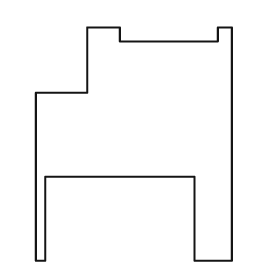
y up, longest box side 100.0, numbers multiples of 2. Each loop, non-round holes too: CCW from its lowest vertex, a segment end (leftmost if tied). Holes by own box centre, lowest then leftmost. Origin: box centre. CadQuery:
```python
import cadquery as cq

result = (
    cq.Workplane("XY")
    .moveTo(-42.0, -50.0)
    .lineTo(-38.0, -50.0)
    .lineTo(-38.0, -14.0)
    .lineTo(26.0, -14.0)
    .lineTo(26.0, -50.0)
    .lineTo(42.0, -50.0)
    .lineTo(42.0, 50.0)
    .lineTo(36.0, 50.0)
    .lineTo(36.0, 44.0)
    .lineTo(-6.0, 44.0)
    .lineTo(-6.0, 50.0)
    .lineTo(-20.0, 50.0)
    .lineTo(-20.0, 22.0)
    .lineTo(-42.0, 22.0)
    .close()
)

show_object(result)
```